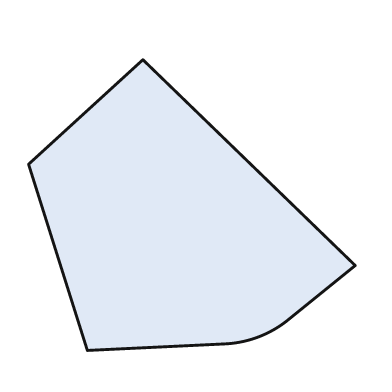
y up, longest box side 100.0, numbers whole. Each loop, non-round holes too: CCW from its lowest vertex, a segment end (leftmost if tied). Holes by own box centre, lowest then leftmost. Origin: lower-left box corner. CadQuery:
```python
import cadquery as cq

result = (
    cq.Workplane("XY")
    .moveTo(18.0, 0.0)
    .lineTo(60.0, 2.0)
    .threePointArc((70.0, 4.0), (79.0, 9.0))
    .lineTo(100.0, 26.0)
    .lineTo(35.0, 89.0)
    .lineTo(0.0, 57.0)
    .close()
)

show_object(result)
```